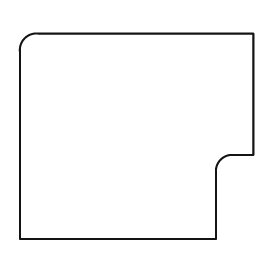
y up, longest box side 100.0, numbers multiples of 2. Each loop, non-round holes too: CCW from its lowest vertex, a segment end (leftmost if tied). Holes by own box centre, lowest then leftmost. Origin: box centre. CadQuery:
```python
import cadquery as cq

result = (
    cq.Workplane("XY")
    .moveTo(-50.0, -44.0)
    .lineTo(34.0, -44.0)
    .lineTo(34.0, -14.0)
    .threePointArc((36.0, -10.0), (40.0, -8.0))
    .lineTo(50.0, -8.0)
    .lineTo(50.0, 44.0)
    .lineTo(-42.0, 44.0)
    .threePointArc((-48.0, 42.0), (-50.0, 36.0))
    .close()
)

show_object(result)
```